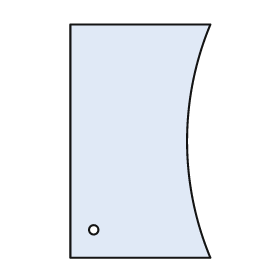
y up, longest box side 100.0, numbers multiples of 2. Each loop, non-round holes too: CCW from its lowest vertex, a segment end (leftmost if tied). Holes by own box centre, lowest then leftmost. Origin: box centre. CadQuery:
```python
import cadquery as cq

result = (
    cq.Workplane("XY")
    .moveTo(-30.0, -50.0)
    .lineTo(30.0, -50.0)
    .threePointArc((20.0, 0.0), (30.0, 50.0))
    .lineTo(-30.0, 50.0)
    .close()
    .moveTo(-20.0, -38.0)
    .circle(2.0)
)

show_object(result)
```